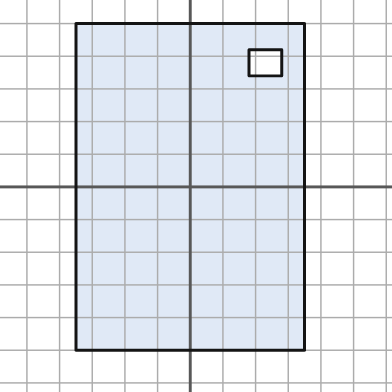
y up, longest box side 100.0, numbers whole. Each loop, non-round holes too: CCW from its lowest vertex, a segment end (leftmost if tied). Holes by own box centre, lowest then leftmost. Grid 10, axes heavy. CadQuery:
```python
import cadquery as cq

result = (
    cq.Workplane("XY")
    .moveTo(-35.0, -50.0)
    .lineTo(35.0, -50.0)
    .lineTo(35.0, 50.0)
    .lineTo(-35.0, 50.0)
    .close()
    .moveTo(18.0, 34.0)
    .lineTo(28.0, 34.0)
    .lineTo(28.0, 42.0)
    .lineTo(18.0, 42.0)
    .close()
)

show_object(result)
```